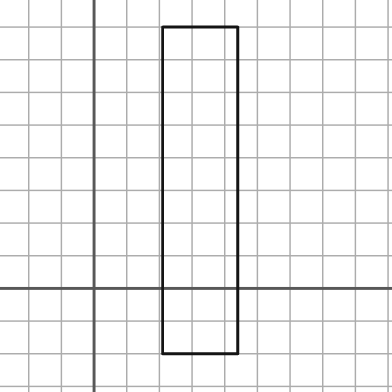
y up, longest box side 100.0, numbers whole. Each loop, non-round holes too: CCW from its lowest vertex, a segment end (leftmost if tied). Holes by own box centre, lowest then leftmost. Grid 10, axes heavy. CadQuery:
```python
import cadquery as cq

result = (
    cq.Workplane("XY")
    .moveTo(21.0, -20.0)
    .lineTo(44.0, -20.0)
    .lineTo(44.0, 80.0)
    .lineTo(21.0, 80.0)
    .close()
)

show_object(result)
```